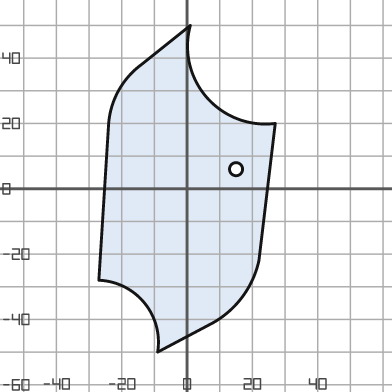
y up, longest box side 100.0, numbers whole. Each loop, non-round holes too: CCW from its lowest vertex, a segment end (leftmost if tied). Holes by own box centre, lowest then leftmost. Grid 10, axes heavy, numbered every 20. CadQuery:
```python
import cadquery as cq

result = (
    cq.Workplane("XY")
    .moveTo(-9.0, -50.0)
    .lineTo(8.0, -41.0)
    .threePointArc((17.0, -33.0), (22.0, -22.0))
    .lineTo(27.0, 20.0)
    .threePointArc((6.0, 28.0), (1.0, 50.0))
    .lineTo(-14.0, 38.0)
    .threePointArc((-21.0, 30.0), (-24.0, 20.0))
    .lineTo(-27.0, -28.0)
    .threePointArc((-13.0, -35.0), (-9.0, -50.0))
    .close()
    .moveTo(15.0, 6.0)
    .circle(2.0)
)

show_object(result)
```